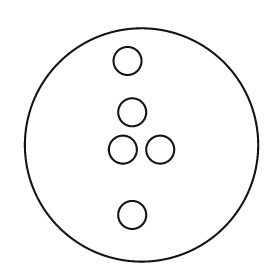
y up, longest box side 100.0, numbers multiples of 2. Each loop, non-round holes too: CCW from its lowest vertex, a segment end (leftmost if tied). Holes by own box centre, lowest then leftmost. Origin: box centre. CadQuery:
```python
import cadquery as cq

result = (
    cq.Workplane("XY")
    .moveTo(0.0, 0.0)
    .circle(50.0)
    .moveTo(-4.0, -30.0)
    .circle(6.0)
    .moveTo(-8.0, -2.0)
    .circle(6.0)
    .moveTo(8.0, -2.0)
    .circle(6.0)
    .moveTo(-4.0, 14.0)
    .circle(6.0)
    .moveTo(-6.0, 36.0)
    .circle(6.0)
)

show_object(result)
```